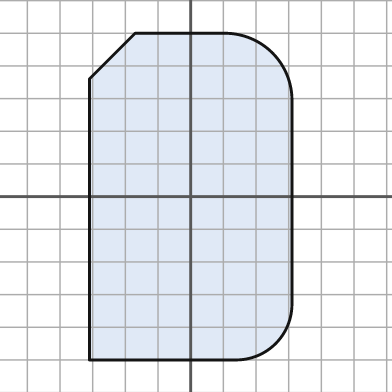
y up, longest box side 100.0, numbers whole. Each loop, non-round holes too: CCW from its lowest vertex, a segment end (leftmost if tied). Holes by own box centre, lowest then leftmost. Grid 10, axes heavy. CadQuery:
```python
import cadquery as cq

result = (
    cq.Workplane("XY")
    .moveTo(-31.0, -50.0)
    .lineTo(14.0, -50.0)
    .threePointArc((26.0, -45.0), (31.0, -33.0))
    .lineTo(31.0, 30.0)
    .threePointArc((25.0, 44.0), (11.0, 50.0))
    .lineTo(-17.0, 50.0)
    .lineTo(-31.0, 36.0)
    .close()
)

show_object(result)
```